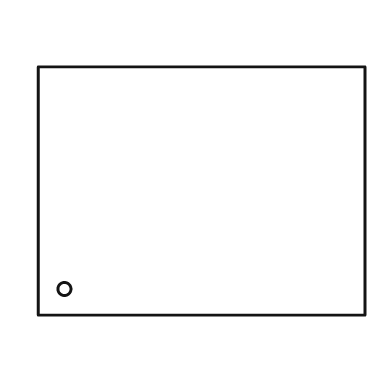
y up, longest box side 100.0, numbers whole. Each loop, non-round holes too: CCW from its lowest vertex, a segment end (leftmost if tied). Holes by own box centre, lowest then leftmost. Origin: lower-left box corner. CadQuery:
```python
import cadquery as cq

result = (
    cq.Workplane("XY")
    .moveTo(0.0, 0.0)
    .lineTo(100.0, 0.0)
    .lineTo(100.0, 76.0)
    .lineTo(0.0, 76.0)
    .close()
    .moveTo(8.0, 8.0)
    .circle(2.0)
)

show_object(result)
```